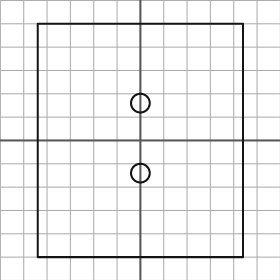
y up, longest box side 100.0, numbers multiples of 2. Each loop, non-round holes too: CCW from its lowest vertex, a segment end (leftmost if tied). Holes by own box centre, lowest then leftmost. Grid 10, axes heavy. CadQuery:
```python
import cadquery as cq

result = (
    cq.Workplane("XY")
    .moveTo(-44.0, -50.0)
    .lineTo(44.0, -50.0)
    .lineTo(44.0, 50.0)
    .lineTo(-44.0, 50.0)
    .close()
    .moveTo(0.0, -14.0)
    .circle(4.0)
    .moveTo(0.0, 16.0)
    .circle(4.0)
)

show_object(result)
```